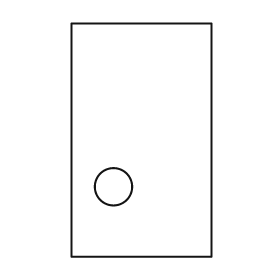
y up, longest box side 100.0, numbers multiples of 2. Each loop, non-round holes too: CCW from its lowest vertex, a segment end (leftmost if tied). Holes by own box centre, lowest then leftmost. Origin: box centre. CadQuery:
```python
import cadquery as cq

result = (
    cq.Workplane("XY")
    .moveTo(-30.0, -50.0)
    .lineTo(30.0, -50.0)
    .lineTo(30.0, 50.0)
    .lineTo(-30.0, 50.0)
    .close()
    .moveTo(-12.0, -20.0)
    .circle(8.0)
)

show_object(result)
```